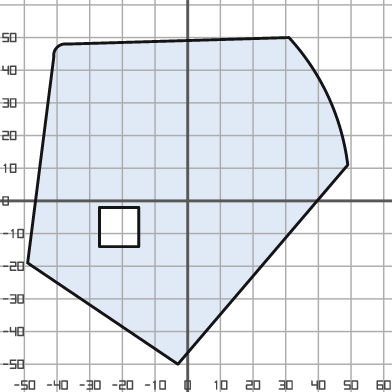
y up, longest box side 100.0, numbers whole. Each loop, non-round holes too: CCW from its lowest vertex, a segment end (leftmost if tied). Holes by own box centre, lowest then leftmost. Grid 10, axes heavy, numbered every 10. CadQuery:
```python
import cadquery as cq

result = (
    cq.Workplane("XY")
    .moveTo(-3.0, -50.0)
    .lineTo(49.0, 11.0)
    .threePointArc((43.0, 32.0), (31.0, 50.0))
    .lineTo(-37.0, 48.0)
    .threePointArc((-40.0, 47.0), (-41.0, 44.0))
    .lineTo(-49.0, -19.0)
    .close()
    .moveTo(-27.0, -14.0)
    .lineTo(-15.0, -14.0)
    .lineTo(-15.0, -2.0)
    .lineTo(-27.0, -2.0)
    .close()
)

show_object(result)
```